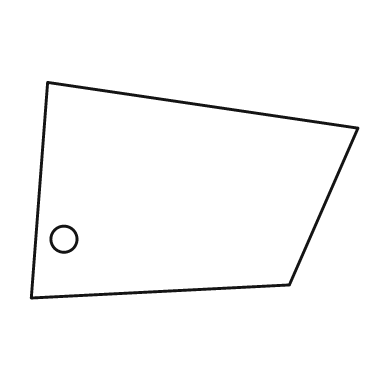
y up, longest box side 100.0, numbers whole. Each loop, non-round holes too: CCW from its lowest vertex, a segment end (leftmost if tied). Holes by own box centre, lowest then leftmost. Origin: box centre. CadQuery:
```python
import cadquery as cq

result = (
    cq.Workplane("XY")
    .moveTo(-50.0, -33.0)
    .lineTo(29.0, -29.0)
    .lineTo(50.0, 19.0)
    .lineTo(-45.0, 33.0)
    .close()
    .moveTo(-40.0, -15.0)
    .circle(4.0)
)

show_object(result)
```